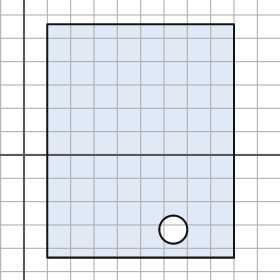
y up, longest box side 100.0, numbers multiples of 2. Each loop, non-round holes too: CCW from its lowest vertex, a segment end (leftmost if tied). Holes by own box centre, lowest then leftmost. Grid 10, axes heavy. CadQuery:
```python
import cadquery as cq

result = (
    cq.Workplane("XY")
    .moveTo(10.0, -44.0)
    .lineTo(90.0, -44.0)
    .lineTo(90.0, 56.0)
    .lineTo(10.0, 56.0)
    .close()
    .moveTo(64.0, -32.0)
    .circle(6.0)
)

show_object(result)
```